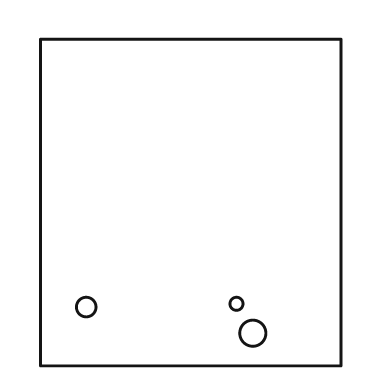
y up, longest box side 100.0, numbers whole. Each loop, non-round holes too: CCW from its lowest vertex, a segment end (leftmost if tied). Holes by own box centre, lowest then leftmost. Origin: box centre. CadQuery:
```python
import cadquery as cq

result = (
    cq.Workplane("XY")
    .moveTo(-46.0, -50.0)
    .lineTo(46.0, -50.0)
    .lineTo(46.0, 50.0)
    .lineTo(-46.0, 50.0)
    .close()
    .moveTo(19.0, -40.0)
    .circle(4.0)
    .moveTo(-32.0, -32.0)
    .circle(3.0)
    .moveTo(14.0, -31.0)
    .circle(2.0)
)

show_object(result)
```